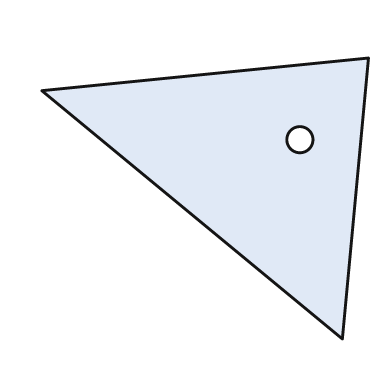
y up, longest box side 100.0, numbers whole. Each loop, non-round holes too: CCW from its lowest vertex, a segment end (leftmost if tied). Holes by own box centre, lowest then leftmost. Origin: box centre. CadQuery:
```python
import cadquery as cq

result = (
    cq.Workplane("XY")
    .moveTo(42.0, -43.0)
    .lineTo(50.0, 43.0)
    .lineTo(-50.0, 33.0)
    .close()
    .moveTo(29.0, 18.0)
    .circle(4.0)
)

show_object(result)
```